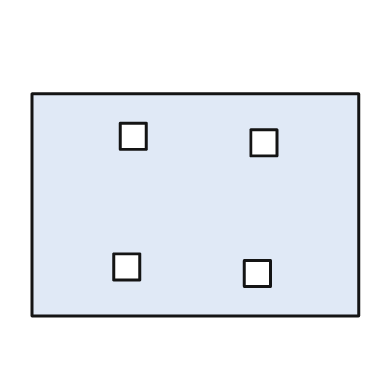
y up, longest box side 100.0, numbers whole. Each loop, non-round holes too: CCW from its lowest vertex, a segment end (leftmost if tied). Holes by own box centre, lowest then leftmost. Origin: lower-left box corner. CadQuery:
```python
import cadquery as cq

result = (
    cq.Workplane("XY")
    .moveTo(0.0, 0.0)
    .lineTo(100.0, 0.0)
    .lineTo(100.0, 68.0)
    .lineTo(0.0, 68.0)
    .close()
    .moveTo(65.0, 9.0)
    .lineTo(73.0, 9.0)
    .lineTo(73.0, 17.0)
    .lineTo(65.0, 17.0)
    .close()
    .moveTo(25.0, 11.0)
    .lineTo(33.0, 11.0)
    .lineTo(33.0, 19.0)
    .lineTo(25.0, 19.0)
    .close()
    .moveTo(67.0, 49.0)
    .lineTo(75.0, 49.0)
    .lineTo(75.0, 57.0)
    .lineTo(67.0, 57.0)
    .close()
    .moveTo(27.0, 51.0)
    .lineTo(35.0, 51.0)
    .lineTo(35.0, 59.0)
    .lineTo(27.0, 59.0)
    .close()
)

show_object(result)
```